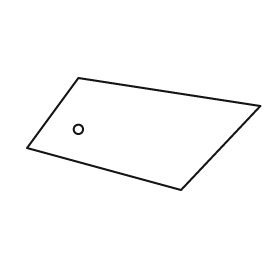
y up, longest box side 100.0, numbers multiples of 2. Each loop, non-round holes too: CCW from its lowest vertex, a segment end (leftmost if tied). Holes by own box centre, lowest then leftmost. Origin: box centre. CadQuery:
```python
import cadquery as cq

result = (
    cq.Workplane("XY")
    .moveTo(16.0, -24.0)
    .lineTo(50.0, 12.0)
    .lineTo(-28.0, 24.0)
    .lineTo(-50.0, -6.0)
    .close()
    .moveTo(-28.0, 2.0)
    .circle(2.0)
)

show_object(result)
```